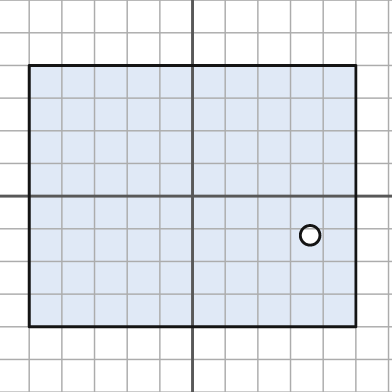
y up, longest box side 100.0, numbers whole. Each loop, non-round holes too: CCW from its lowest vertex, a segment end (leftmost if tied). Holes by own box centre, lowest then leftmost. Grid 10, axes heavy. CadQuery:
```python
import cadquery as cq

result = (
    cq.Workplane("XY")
    .moveTo(-50.0, -40.0)
    .lineTo(50.0, -40.0)
    .lineTo(50.0, 40.0)
    .lineTo(-50.0, 40.0)
    .close()
    .moveTo(36.0, -12.0)
    .circle(3.0)
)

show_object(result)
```